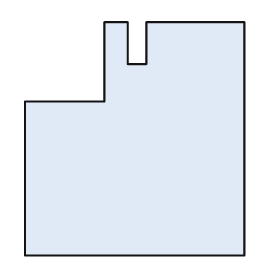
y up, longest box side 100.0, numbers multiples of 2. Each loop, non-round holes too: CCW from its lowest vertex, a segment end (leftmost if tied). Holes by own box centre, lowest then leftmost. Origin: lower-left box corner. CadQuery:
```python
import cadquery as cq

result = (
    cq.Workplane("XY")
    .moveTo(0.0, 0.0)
    .lineTo(94.0, 0.0)
    .lineTo(94.0, 100.0)
    .lineTo(52.0, 100.0)
    .lineTo(52.0, 82.0)
    .lineTo(44.0, 82.0)
    .lineTo(44.0, 100.0)
    .lineTo(34.0, 100.0)
    .lineTo(34.0, 66.0)
    .lineTo(0.0, 66.0)
    .close()
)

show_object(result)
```